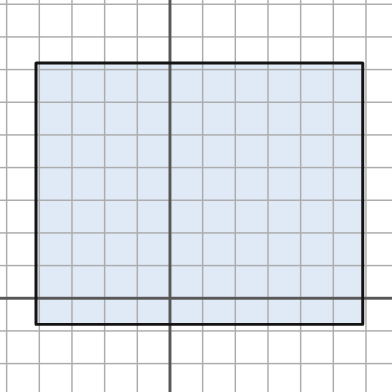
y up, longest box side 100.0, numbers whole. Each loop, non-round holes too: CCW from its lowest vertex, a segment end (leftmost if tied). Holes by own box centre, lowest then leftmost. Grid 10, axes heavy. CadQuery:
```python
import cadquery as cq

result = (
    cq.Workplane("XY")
    .moveTo(-41.0, -8.0)
    .lineTo(59.0, -8.0)
    .lineTo(59.0, 72.0)
    .lineTo(-41.0, 72.0)
    .close()
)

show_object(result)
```